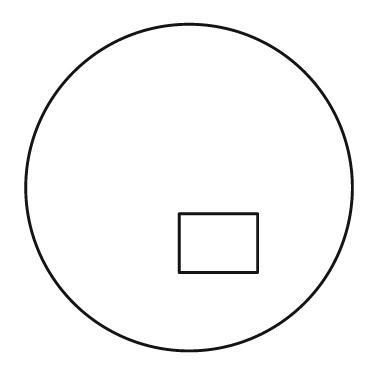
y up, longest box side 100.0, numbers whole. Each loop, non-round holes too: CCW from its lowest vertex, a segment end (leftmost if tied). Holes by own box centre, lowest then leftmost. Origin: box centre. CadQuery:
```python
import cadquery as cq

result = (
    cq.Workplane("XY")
    .moveTo(0.0, 0.0)
    .circle(50.0)
    .moveTo(-3.0, -26.0)
    .lineTo(21.0, -26.0)
    .lineTo(21.0, -8.0)
    .lineTo(-3.0, -8.0)
    .close()
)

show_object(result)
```